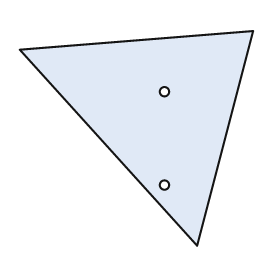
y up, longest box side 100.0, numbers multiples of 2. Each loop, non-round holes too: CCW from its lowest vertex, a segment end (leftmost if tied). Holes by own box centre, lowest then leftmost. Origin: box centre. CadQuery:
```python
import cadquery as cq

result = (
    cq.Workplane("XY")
    .moveTo(26.0, -46.0)
    .lineTo(50.0, 46.0)
    .lineTo(-50.0, 38.0)
    .close()
    .moveTo(12.0, -20.0)
    .circle(2.0)
    .moveTo(12.0, 20.0)
    .circle(2.0)
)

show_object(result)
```